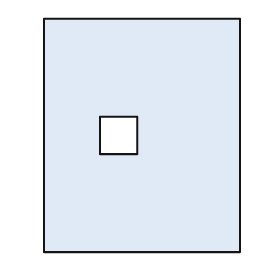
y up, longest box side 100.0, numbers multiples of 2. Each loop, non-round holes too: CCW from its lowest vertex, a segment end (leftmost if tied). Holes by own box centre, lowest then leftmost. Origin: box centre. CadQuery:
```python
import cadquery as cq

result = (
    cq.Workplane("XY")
    .moveTo(-42.0, -50.0)
    .lineTo(42.0, -50.0)
    .lineTo(42.0, 50.0)
    .lineTo(-42.0, 50.0)
    .close()
    .moveTo(-18.0, -8.0)
    .lineTo(-2.0, -8.0)
    .lineTo(-2.0, 8.0)
    .lineTo(-18.0, 8.0)
    .close()
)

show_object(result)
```